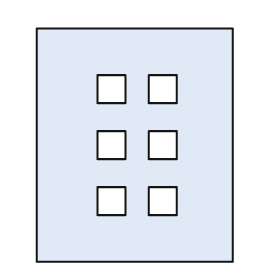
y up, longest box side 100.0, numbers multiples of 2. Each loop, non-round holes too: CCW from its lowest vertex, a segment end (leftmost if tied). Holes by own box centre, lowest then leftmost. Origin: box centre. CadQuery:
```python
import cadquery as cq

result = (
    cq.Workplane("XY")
    .moveTo(-42.0, -50.0)
    .lineTo(42.0, -50.0)
    .lineTo(42.0, 50.0)
    .lineTo(-42.0, 50.0)
    .close()
    .moveTo(-16.0, -30.0)
    .lineTo(-4.0, -30.0)
    .lineTo(-4.0, -18.0)
    .lineTo(-16.0, -18.0)
    .close()
    .moveTo(6.0, -30.0)
    .lineTo(18.0, -30.0)
    .lineTo(18.0, -18.0)
    .lineTo(6.0, -18.0)
    .close()
    .moveTo(-16.0, -6.0)
    .lineTo(-4.0, -6.0)
    .lineTo(-4.0, 6.0)
    .lineTo(-16.0, 6.0)
    .close()
    .moveTo(6.0, -6.0)
    .lineTo(18.0, -6.0)
    .lineTo(18.0, 6.0)
    .lineTo(6.0, 6.0)
    .close()
    .moveTo(-16.0, 18.0)
    .lineTo(-4.0, 18.0)
    .lineTo(-4.0, 30.0)
    .lineTo(-16.0, 30.0)
    .close()
    .moveTo(6.0, 18.0)
    .lineTo(18.0, 18.0)
    .lineTo(18.0, 30.0)
    .lineTo(6.0, 30.0)
    .close()
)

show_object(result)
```